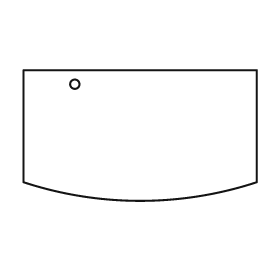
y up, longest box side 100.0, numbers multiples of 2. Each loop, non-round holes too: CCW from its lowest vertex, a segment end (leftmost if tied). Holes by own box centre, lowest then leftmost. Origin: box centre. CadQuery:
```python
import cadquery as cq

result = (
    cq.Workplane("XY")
    .moveTo(-50.0, -20.0)
    .threePointArc((0.0, -28.0), (50.0, -20.0))
    .lineTo(50.0, 28.0)
    .lineTo(-50.0, 28.0)
    .close()
    .moveTo(-28.0, 22.0)
    .circle(2.0)
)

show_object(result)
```